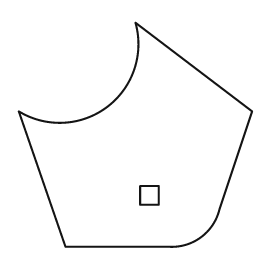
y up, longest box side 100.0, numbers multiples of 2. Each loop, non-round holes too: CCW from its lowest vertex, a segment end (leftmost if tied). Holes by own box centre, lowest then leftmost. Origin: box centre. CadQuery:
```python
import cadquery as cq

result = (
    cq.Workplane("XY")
    .moveTo(-30.0, -48.0)
    .lineTo(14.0, -48.0)
    .threePointArc((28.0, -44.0), (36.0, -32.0))
    .lineTo(50.0, 10.0)
    .lineTo(0.0, 48.0)
    .threePointArc((-12.0, 12.0), (-50.0, 10.0))
    .close()
    .moveTo(2.0, -30.0)
    .lineTo(10.0, -30.0)
    .lineTo(10.0, -22.0)
    .lineTo(2.0, -22.0)
    .close()
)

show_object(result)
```